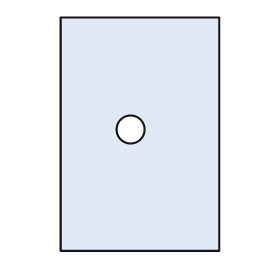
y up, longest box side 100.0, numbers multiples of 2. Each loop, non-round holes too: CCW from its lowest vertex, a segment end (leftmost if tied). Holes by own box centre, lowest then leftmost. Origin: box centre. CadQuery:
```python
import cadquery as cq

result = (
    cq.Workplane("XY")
    .moveTo(-34.0, -50.0)
    .lineTo(34.0, -50.0)
    .lineTo(34.0, 50.0)
    .lineTo(-34.0, 50.0)
    .close()
    .moveTo(-4.0, 2.0)
    .circle(6.0)
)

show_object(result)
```